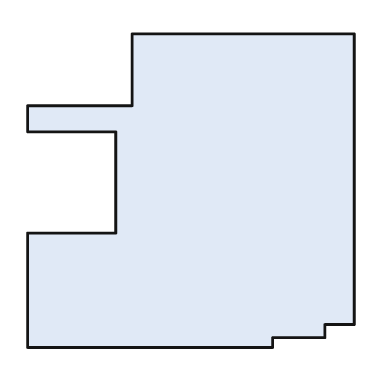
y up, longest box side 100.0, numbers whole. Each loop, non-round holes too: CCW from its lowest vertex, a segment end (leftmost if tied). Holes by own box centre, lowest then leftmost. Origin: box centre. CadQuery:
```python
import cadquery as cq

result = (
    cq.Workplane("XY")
    .moveTo(-50.0, -48.0)
    .lineTo(25.0, -48.0)
    .lineTo(25.0, -45.0)
    .lineTo(41.0, -45.0)
    .lineTo(41.0, -41.0)
    .lineTo(50.0, -41.0)
    .lineTo(50.0, 48.0)
    .lineTo(-18.0, 48.0)
    .lineTo(-18.0, 26.0)
    .lineTo(-50.0, 26.0)
    .lineTo(-50.0, 18.0)
    .lineTo(-23.0, 18.0)
    .lineTo(-23.0, -13.0)
    .lineTo(-50.0, -13.0)
    .close()
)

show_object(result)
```